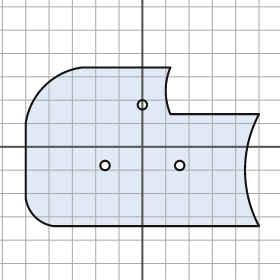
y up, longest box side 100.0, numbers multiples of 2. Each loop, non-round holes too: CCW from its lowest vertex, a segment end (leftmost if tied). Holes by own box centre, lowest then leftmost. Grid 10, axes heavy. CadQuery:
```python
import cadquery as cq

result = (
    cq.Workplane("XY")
    .moveTo(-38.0, -34.0)
    .lineTo(50.0, -34.0)
    .threePointArc((44.0, -10.0), (50.0, 14.0))
    .lineTo(12.0, 14.0)
    .threePointArc((10.0, 24.0), (12.0, 34.0))
    .lineTo(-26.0, 34.0)
    .threePointArc((-42.0, 26.0), (-50.0, 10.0))
    .lineTo(-50.0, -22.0)
    .threePointArc((-46.0, -30.0), (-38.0, -34.0))
    .close()
    .moveTo(-16.0, -8.0)
    .circle(2.0)
    .moveTo(16.0, -8.0)
    .circle(2.0)
    .moveTo(0.0, 18.0)
    .circle(2.0)
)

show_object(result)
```